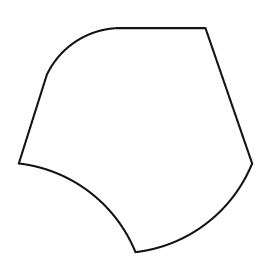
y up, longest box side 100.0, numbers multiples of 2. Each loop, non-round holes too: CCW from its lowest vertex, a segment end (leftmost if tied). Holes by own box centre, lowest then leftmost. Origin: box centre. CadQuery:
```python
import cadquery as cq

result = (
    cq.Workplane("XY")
    .moveTo(0.0, -48.0)
    .threePointArc((30.0, -36.0), (50.0, -10.0))
    .lineTo(30.0, 48.0)
    .lineTo(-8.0, 48.0)
    .threePointArc((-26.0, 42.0), (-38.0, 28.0))
    .lineTo(-50.0, -10.0)
    .threePointArc((-20.0, -22.0), (0.0, -48.0))
    .close()
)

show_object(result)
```